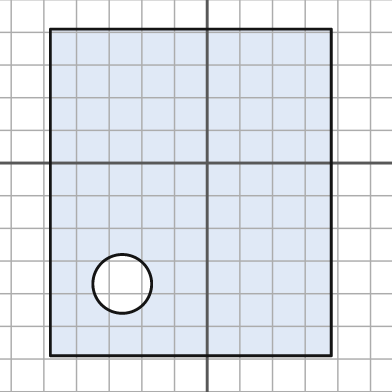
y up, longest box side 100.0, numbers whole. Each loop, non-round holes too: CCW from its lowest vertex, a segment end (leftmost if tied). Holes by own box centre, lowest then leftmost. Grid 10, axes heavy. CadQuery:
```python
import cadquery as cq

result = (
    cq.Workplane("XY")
    .moveTo(-48.0, -59.0)
    .lineTo(38.0, -59.0)
    .lineTo(38.0, 41.0)
    .lineTo(-48.0, 41.0)
    .close()
    .moveTo(-26.0, -37.0)
    .circle(9.0)
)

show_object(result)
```